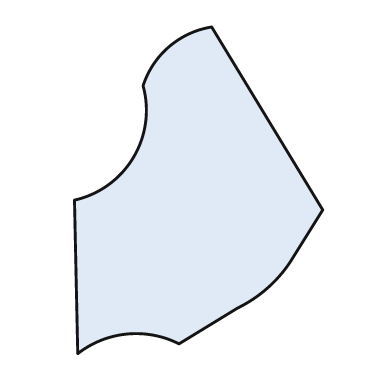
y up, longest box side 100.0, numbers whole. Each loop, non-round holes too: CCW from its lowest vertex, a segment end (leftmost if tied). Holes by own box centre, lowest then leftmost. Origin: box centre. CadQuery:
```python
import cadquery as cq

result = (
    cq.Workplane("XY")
    .moveTo(-37.0, -50.0)
    .threePointArc((-22.0, -44.0), (-6.0, -47.0))
    .lineTo(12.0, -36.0)
    .threePointArc((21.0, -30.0), (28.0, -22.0))
    .lineTo(38.0, -6.0)
    .lineTo(4.0, 50.0)
    .threePointArc((-9.0, 44.0), (-17.0, 32.0))
    .threePointArc((-20.0, 10.0), (-38.0, -3.0))
    .close()
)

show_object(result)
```